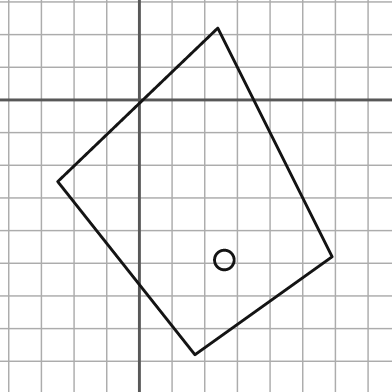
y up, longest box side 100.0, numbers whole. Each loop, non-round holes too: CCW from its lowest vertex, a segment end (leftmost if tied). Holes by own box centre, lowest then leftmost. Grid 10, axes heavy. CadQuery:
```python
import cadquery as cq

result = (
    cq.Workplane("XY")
    .moveTo(17.0, -78.0)
    .lineTo(59.0, -48.0)
    .lineTo(24.0, 22.0)
    .lineTo(-25.0, -25.0)
    .close()
    .moveTo(26.0, -49.0)
    .circle(3.0)
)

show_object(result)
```